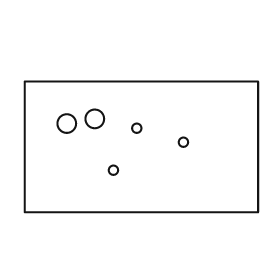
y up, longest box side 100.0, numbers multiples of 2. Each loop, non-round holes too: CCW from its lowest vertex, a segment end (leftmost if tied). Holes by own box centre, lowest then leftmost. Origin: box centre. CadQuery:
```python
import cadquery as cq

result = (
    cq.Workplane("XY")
    .moveTo(-50.0, -28.0)
    .lineTo(50.0, -28.0)
    .lineTo(50.0, 28.0)
    .lineTo(-50.0, 28.0)
    .close()
    .moveTo(-12.0, -10.0)
    .circle(2.0)
    .moveTo(18.0, 2.0)
    .circle(2.0)
    .moveTo(-2.0, 8.0)
    .circle(2.0)
    .moveTo(-32.0, 10.0)
    .circle(4.0)
    .moveTo(-20.0, 12.0)
    .circle(4.0)
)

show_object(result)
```